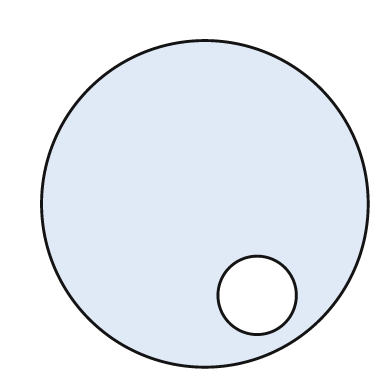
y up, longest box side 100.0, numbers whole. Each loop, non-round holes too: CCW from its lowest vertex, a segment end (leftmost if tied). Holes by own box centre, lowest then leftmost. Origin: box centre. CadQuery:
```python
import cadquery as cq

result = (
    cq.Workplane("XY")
    .moveTo(0.0, 0.0)
    .circle(50.0)
    .moveTo(16.0, -28.0)
    .circle(12.0)
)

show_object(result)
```